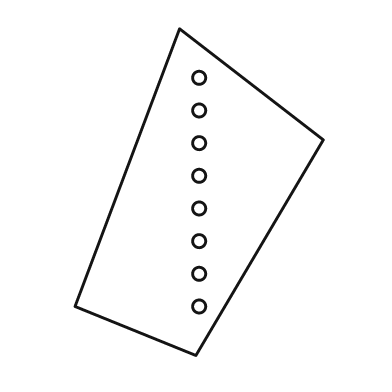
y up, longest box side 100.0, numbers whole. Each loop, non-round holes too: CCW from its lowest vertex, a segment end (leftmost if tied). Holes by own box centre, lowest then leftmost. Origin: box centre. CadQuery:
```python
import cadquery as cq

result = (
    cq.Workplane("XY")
    .moveTo(-1.0, -50.0)
    .lineTo(38.0, 16.0)
    .lineTo(-6.0, 50.0)
    .lineTo(-38.0, -35.0)
    .close()
    .moveTo(0.0, -35.0)
    .circle(2.0)
    .moveTo(0.0, -25.0)
    .circle(2.0)
    .moveTo(0.0, -15.0)
    .circle(2.0)
    .moveTo(0.0, -5.0)
    .circle(2.0)
    .moveTo(0.0, 5.0)
    .circle(2.0)
    .moveTo(0.0, 15.0)
    .circle(2.0)
    .moveTo(0.0, 25.0)
    .circle(2.0)
    .moveTo(0.0, 35.0)
    .circle(2.0)
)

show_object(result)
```